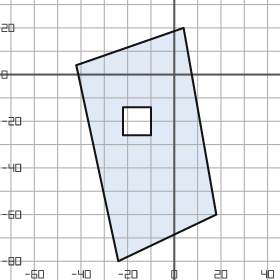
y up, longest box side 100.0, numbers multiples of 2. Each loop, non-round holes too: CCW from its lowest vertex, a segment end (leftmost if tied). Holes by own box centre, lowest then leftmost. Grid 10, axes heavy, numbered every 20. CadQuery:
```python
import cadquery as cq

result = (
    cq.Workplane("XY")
    .moveTo(-24.0, -80.0)
    .lineTo(18.0, -60.0)
    .lineTo(4.0, 20.0)
    .lineTo(-42.0, 4.0)
    .close()
    .moveTo(-22.0, -26.0)
    .lineTo(-10.0, -26.0)
    .lineTo(-10.0, -14.0)
    .lineTo(-22.0, -14.0)
    .close()
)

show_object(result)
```